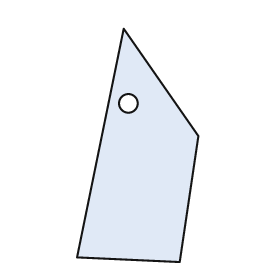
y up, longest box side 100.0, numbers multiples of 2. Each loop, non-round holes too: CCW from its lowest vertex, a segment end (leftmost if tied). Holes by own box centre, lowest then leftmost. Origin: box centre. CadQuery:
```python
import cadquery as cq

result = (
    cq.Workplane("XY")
    .moveTo(18.0, -50.0)
    .lineTo(26.0, 4.0)
    .lineTo(-6.0, 50.0)
    .lineTo(-26.0, -48.0)
    .close()
    .moveTo(-4.0, 18.0)
    .circle(4.0)
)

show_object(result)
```